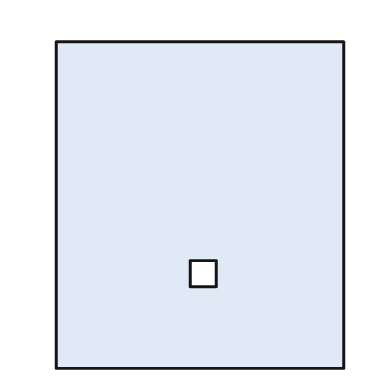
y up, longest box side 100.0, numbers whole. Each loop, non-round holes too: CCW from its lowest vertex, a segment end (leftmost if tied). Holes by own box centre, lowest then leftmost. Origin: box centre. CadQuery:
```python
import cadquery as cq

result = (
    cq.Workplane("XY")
    .moveTo(-44.0, -50.0)
    .lineTo(44.0, -50.0)
    .lineTo(44.0, 50.0)
    .lineTo(-44.0, 50.0)
    .close()
    .moveTo(-3.0, -25.0)
    .lineTo(5.0, -25.0)
    .lineTo(5.0, -17.0)
    .lineTo(-3.0, -17.0)
    .close()
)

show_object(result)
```